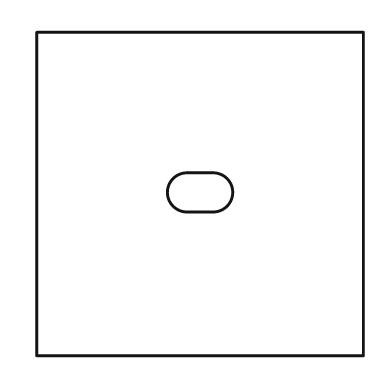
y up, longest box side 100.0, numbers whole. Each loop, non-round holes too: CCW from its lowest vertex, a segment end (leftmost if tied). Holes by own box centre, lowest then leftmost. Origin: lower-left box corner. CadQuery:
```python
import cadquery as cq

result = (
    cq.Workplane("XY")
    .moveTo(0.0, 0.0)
    .lineTo(100.0, 0.0)
    .lineTo(100.0, 99.0)
    .lineTo(0.0, 99.0)
    .close()
    .moveTo(46.0, 44.0)
    .lineTo(54.0, 44.0)
    .threePointArc((60.0, 50.0), (54.0, 56.0))
    .lineTo(46.0, 56.0)
    .threePointArc((40.0, 50.0), (46.0, 44.0))
    .close()
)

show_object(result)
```